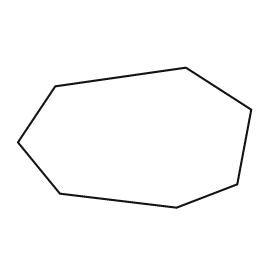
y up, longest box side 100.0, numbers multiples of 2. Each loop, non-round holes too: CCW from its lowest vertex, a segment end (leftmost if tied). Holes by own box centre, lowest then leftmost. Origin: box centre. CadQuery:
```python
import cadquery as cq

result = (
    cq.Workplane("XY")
    .moveTo(18.0, -30.0)
    .lineTo(44.0, -20.0)
    .lineTo(50.0, 12.0)
    .lineTo(22.0, 30.0)
    .lineTo(-34.0, 22.0)
    .lineTo(-50.0, -2.0)
    .lineTo(-32.0, -24.0)
    .close()
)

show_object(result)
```